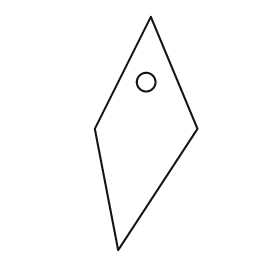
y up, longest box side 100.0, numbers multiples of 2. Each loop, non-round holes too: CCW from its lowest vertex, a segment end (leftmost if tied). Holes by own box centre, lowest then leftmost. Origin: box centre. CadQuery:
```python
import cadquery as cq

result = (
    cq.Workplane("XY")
    .moveTo(-12.0, -50.0)
    .lineTo(22.0, 2.0)
    .lineTo(2.0, 50.0)
    .lineTo(-22.0, 2.0)
    .close()
    .moveTo(0.0, 22.0)
    .circle(4.0)
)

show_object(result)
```